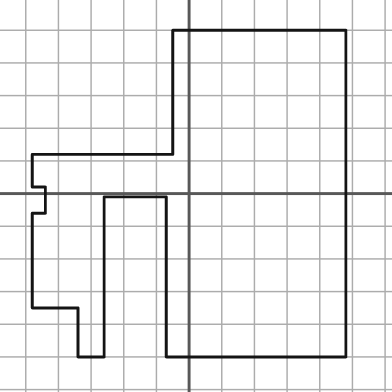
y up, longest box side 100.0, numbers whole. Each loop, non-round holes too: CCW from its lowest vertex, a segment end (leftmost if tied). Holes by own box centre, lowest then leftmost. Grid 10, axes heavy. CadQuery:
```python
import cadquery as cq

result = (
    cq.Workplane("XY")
    .moveTo(-34.0, -50.0)
    .lineTo(-26.0, -50.0)
    .lineTo(-26.0, -1.0)
    .lineTo(-7.0, -1.0)
    .lineTo(-7.0, -50.0)
    .lineTo(48.0, -50.0)
    .lineTo(48.0, 50.0)
    .lineTo(-5.0, 50.0)
    .lineTo(-5.0, 12.0)
    .lineTo(-48.0, 12.0)
    .lineTo(-48.0, 2.0)
    .lineTo(-44.0, 2.0)
    .lineTo(-44.0, -6.0)
    .lineTo(-48.0, -6.0)
    .lineTo(-48.0, -35.0)
    .lineTo(-34.0, -35.0)
    .close()
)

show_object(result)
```